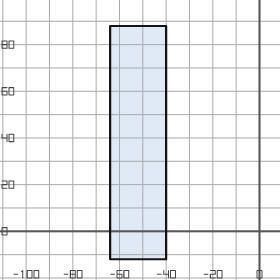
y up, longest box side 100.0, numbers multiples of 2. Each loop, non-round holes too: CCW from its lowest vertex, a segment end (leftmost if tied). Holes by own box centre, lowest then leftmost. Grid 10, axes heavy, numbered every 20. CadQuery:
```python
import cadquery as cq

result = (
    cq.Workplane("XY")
    .moveTo(-64.0, -12.0)
    .lineTo(-40.0, -12.0)
    .lineTo(-40.0, 88.0)
    .lineTo(-64.0, 88.0)
    .close()
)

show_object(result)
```